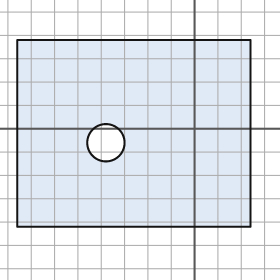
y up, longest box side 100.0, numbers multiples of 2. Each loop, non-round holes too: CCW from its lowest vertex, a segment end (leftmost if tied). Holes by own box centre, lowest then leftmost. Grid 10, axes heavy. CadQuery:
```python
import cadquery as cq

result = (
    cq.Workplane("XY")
    .moveTo(-76.0, -42.0)
    .lineTo(24.0, -42.0)
    .lineTo(24.0, 38.0)
    .lineTo(-76.0, 38.0)
    .close()
    .moveTo(-38.0, -6.0)
    .circle(8.0)
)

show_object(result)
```